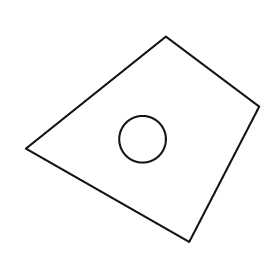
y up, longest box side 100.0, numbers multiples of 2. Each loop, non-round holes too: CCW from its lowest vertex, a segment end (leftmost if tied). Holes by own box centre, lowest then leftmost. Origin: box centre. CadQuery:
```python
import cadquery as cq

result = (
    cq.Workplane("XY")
    .moveTo(20.0, -44.0)
    .lineTo(50.0, 14.0)
    .lineTo(10.0, 44.0)
    .lineTo(-50.0, -4.0)
    .close()
    .moveTo(0.0, 0.0)
    .circle(10.0)
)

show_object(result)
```